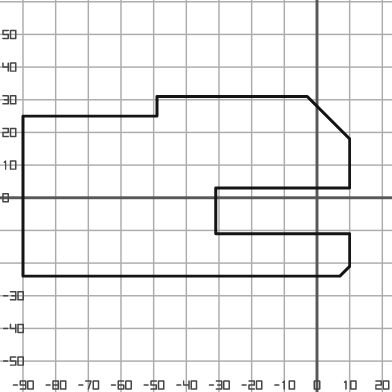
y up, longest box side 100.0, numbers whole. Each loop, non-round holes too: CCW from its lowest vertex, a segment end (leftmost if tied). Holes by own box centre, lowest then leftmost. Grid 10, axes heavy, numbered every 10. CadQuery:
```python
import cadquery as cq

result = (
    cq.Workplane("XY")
    .moveTo(-90.0, -24.0)
    .lineTo(7.0, -24.0)
    .lineTo(10.0, -21.0)
    .lineTo(10.0, -11.0)
    .lineTo(-31.0, -11.0)
    .lineTo(-31.0, 3.0)
    .lineTo(10.0, 3.0)
    .lineTo(10.0, 18.0)
    .lineTo(-3.0, 31.0)
    .lineTo(-49.0, 31.0)
    .lineTo(-49.0, 25.0)
    .lineTo(-90.0, 25.0)
    .close()
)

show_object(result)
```